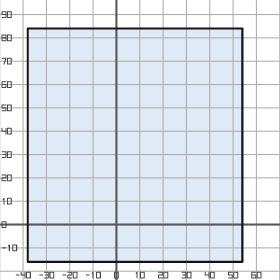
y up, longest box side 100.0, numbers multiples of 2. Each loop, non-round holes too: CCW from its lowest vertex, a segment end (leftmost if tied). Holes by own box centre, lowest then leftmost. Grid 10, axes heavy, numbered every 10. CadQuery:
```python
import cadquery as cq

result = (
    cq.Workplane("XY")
    .moveTo(-38.0, -16.0)
    .lineTo(54.0, -16.0)
    .lineTo(54.0, 84.0)
    .lineTo(-38.0, 84.0)
    .close()
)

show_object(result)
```